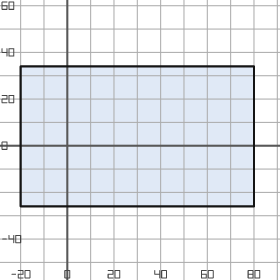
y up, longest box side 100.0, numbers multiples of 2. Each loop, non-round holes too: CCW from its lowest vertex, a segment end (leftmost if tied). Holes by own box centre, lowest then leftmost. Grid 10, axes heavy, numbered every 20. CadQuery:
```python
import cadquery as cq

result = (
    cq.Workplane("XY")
    .moveTo(-20.0, -26.0)
    .lineTo(80.0, -26.0)
    .lineTo(80.0, 34.0)
    .lineTo(-20.0, 34.0)
    .close()
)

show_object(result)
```